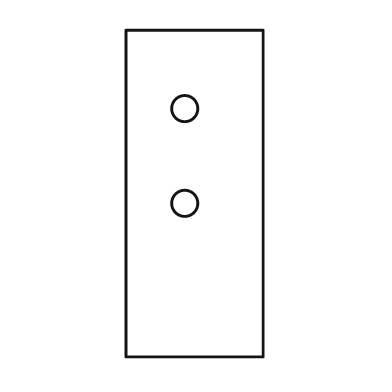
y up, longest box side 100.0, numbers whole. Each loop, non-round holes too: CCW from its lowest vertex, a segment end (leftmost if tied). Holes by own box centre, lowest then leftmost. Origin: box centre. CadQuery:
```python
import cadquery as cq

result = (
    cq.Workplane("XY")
    .moveTo(-21.0, -50.0)
    .lineTo(21.0, -50.0)
    .lineTo(21.0, 50.0)
    .lineTo(-21.0, 50.0)
    .close()
    .moveTo(-3.0, -3.0)
    .circle(4.0)
    .moveTo(-3.0, 26.0)
    .circle(4.0)
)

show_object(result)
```